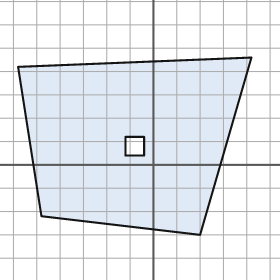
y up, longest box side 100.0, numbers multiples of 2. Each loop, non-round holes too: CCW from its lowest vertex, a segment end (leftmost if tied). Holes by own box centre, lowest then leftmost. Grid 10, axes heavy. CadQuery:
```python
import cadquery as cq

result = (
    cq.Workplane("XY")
    .moveTo(20.0, -30.0)
    .lineTo(42.0, 46.0)
    .lineTo(-58.0, 42.0)
    .lineTo(-48.0, -22.0)
    .close()
    .moveTo(-12.0, 4.0)
    .lineTo(-4.0, 4.0)
    .lineTo(-4.0, 12.0)
    .lineTo(-12.0, 12.0)
    .close()
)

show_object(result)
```